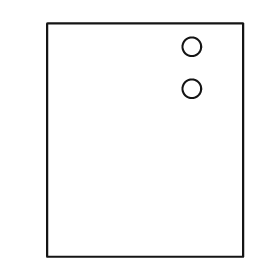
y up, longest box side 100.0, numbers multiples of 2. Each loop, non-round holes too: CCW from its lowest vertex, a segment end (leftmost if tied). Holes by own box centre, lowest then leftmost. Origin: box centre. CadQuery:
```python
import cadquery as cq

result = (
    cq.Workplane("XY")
    .moveTo(-42.0, -50.0)
    .lineTo(42.0, -50.0)
    .lineTo(42.0, 50.0)
    .lineTo(-42.0, 50.0)
    .close()
    .moveTo(20.0, 22.0)
    .circle(4.0)
    .moveTo(20.0, 40.0)
    .circle(4.0)
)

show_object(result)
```